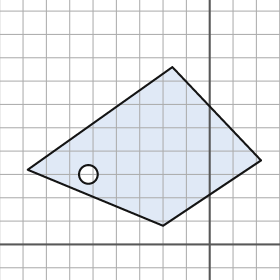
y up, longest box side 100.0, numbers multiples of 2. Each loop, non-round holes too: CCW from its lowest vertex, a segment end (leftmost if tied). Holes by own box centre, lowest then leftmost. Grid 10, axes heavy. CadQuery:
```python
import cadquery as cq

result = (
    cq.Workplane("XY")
    .moveTo(-20.0, 8.0)
    .lineTo(22.0, 36.0)
    .lineTo(-16.0, 76.0)
    .lineTo(-78.0, 32.0)
    .close()
    .moveTo(-52.0, 30.0)
    .circle(4.0)
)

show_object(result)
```